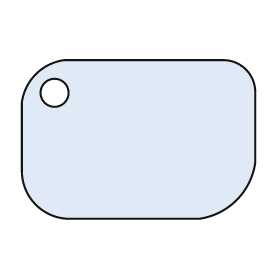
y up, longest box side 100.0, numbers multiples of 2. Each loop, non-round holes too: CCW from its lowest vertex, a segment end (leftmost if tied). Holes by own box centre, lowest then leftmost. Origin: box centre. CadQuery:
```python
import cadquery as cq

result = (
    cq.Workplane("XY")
    .moveTo(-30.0, -34.0)
    .lineTo(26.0, -34.0)
    .threePointArc((42.0, -26.0), (50.0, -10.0))
    .lineTo(50.0, 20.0)
    .threePointArc((46.0, 30.0), (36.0, 34.0))
    .lineTo(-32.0, 34.0)
    .threePointArc((-44.0, 28.0), (-50.0, 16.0))
    .lineTo(-50.0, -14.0)
    .threePointArc((-44.0, -28.0), (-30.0, -34.0))
    .close()
    .moveTo(-36.0, 20.0)
    .circle(6.0)
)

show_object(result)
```